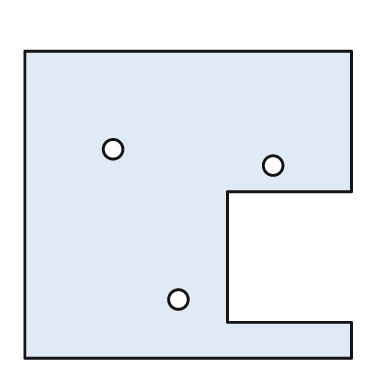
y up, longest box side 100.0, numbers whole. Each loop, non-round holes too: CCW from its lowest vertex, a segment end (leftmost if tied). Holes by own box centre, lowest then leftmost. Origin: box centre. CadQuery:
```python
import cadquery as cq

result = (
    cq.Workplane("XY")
    .moveTo(-50.0, -47.0)
    .lineTo(50.0, -47.0)
    .lineTo(50.0, -36.0)
    .lineTo(12.0, -36.0)
    .lineTo(12.0, 4.0)
    .lineTo(50.0, 4.0)
    .lineTo(50.0, 47.0)
    .lineTo(-50.0, 47.0)
    .close()
    .moveTo(-3.0, -29.0)
    .circle(3.0)
    .moveTo(26.0, 12.0)
    .circle(3.0)
    .moveTo(-23.0, 17.0)
    .circle(3.0)
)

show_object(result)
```